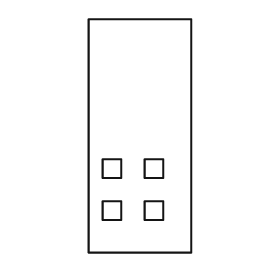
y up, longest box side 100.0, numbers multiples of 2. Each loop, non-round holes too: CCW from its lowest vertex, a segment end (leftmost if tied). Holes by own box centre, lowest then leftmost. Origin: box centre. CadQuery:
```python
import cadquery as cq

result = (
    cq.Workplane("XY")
    .moveTo(-22.0, -50.0)
    .lineTo(22.0, -50.0)
    .lineTo(22.0, 50.0)
    .lineTo(-22.0, 50.0)
    .close()
    .moveTo(-16.0, -36.0)
    .lineTo(-8.0, -36.0)
    .lineTo(-8.0, -28.0)
    .lineTo(-16.0, -28.0)
    .close()
    .moveTo(2.0, -36.0)
    .lineTo(10.0, -36.0)
    .lineTo(10.0, -28.0)
    .lineTo(2.0, -28.0)
    .close()
    .moveTo(-16.0, -18.0)
    .lineTo(-8.0, -18.0)
    .lineTo(-8.0, -10.0)
    .lineTo(-16.0, -10.0)
    .close()
    .moveTo(2.0, -18.0)
    .lineTo(10.0, -18.0)
    .lineTo(10.0, -10.0)
    .lineTo(2.0, -10.0)
    .close()
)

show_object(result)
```